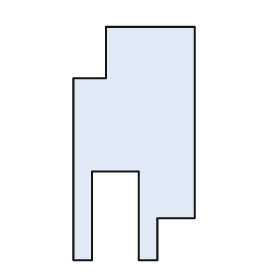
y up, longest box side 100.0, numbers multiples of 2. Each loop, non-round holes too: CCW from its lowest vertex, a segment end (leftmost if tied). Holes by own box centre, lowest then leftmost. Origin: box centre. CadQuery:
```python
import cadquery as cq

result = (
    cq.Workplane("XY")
    .moveTo(-26.0, -50.0)
    .lineTo(-18.0, -50.0)
    .lineTo(-18.0, -12.0)
    .lineTo(2.0, -12.0)
    .lineTo(2.0, -50.0)
    .lineTo(10.0, -50.0)
    .lineTo(10.0, -32.0)
    .lineTo(26.0, -32.0)
    .lineTo(26.0, 50.0)
    .lineTo(-12.0, 50.0)
    .lineTo(-12.0, 28.0)
    .lineTo(-26.0, 28.0)
    .close()
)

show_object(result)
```